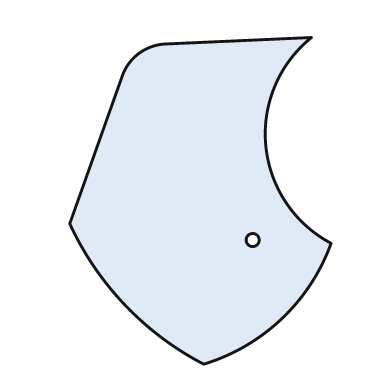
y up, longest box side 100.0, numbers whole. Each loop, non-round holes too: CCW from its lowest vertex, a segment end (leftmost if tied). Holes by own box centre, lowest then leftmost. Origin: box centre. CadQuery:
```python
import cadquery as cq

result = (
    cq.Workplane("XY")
    .moveTo(1.0, -50.0)
    .threePointArc((25.0, -36.0), (40.0, -13.0))
    .threePointArc((20.0, 17.0), (34.0, 50.0))
    .lineTo(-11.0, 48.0)
    .threePointArc((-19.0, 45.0), (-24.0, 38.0))
    .lineTo(-40.0, -7.0)
    .threePointArc((-23.0, -32.0), (1.0, -50.0))
    .close()
    .moveTo(16.0, -12.0)
    .circle(2.0)
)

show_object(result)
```